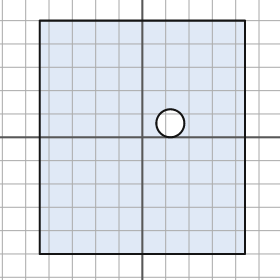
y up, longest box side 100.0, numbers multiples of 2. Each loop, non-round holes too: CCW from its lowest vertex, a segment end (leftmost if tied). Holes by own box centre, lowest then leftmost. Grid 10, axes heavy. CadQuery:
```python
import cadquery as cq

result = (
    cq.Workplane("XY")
    .moveTo(-44.0, -50.0)
    .lineTo(44.0, -50.0)
    .lineTo(44.0, 50.0)
    .lineTo(-44.0, 50.0)
    .close()
    .moveTo(12.0, 6.0)
    .circle(6.0)
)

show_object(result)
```